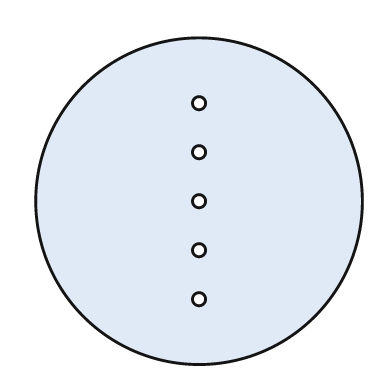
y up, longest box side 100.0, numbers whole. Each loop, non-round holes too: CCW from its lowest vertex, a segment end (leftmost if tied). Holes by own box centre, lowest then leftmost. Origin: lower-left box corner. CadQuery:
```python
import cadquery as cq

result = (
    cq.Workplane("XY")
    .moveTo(50.0, 50.0)
    .circle(50.0)
    .moveTo(50.0, 20.0)
    .circle(2.0)
    .moveTo(50.0, 35.0)
    .circle(2.0)
    .moveTo(50.0, 50.0)
    .circle(2.0)
    .moveTo(50.0, 65.0)
    .circle(2.0)
    .moveTo(50.0, 80.0)
    .circle(2.0)
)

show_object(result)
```